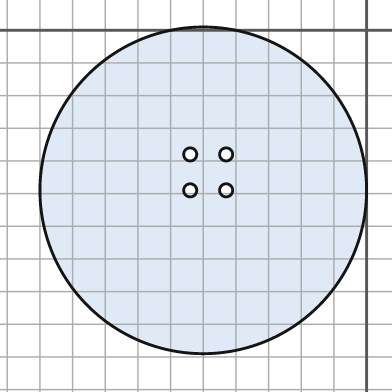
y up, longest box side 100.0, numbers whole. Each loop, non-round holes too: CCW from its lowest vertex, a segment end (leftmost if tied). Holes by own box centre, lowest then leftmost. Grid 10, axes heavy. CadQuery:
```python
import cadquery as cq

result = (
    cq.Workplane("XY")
    .moveTo(-50.0, -49.0)
    .circle(50.0)
    .moveTo(-54.0, -49.0)
    .circle(2.0)
    .moveTo(-43.0, -49.0)
    .circle(2.0)
    .moveTo(-54.0, -38.0)
    .circle(2.0)
    .moveTo(-43.0, -38.0)
    .circle(2.0)
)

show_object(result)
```